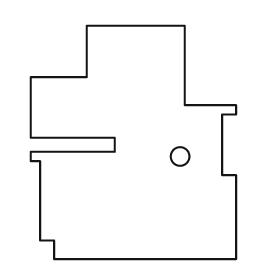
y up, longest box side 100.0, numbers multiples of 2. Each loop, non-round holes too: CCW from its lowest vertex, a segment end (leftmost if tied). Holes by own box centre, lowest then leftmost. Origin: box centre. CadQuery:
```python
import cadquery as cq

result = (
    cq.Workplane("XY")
    .moveTo(-34.0, -50.0)
    .lineTo(44.0, -50.0)
    .lineTo(44.0, -14.0)
    .lineTo(38.0, -14.0)
    .lineTo(38.0, 12.0)
    .lineTo(44.0, 12.0)
    .lineTo(44.0, 16.0)
    .lineTo(22.0, 16.0)
    .lineTo(22.0, 50.0)
    .lineTo(-20.0, 50.0)
    .lineTo(-20.0, 28.0)
    .lineTo(-44.0, 28.0)
    .lineTo(-44.0, 2.0)
    .lineTo(-8.0, 2.0)
    .lineTo(-8.0, -4.0)
    .lineTo(-44.0, -4.0)
    .lineTo(-44.0, -8.0)
    .lineTo(-40.0, -8.0)
    .lineTo(-40.0, -42.0)
    .lineTo(-34.0, -42.0)
    .close()
    .moveTo(20.0, -6.0)
    .circle(4.0)
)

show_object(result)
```